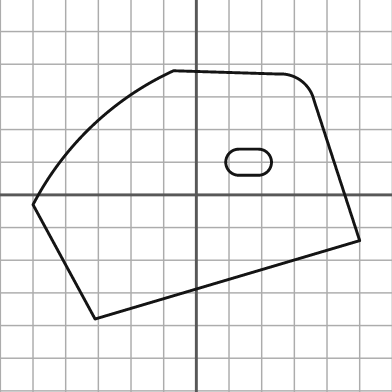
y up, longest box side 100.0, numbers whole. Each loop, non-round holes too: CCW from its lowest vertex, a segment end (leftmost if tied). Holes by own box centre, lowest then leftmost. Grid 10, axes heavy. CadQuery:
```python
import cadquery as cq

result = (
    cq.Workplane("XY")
    .moveTo(-31.0, -38.0)
    .lineTo(50.0, -14.0)
    .lineTo(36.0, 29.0)
    .threePointArc((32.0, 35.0), (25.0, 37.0))
    .lineTo(-7.0, 38.0)
    .threePointArc((-32.0, 21.0), (-50.0, -3.0))
    .close()
    .moveTo(13.0, 6.0)
    .lineTo(19.0, 6.0)
    .threePointArc((23.0, 10.0), (19.0, 14.0))
    .lineTo(13.0, 14.0)
    .threePointArc((9.0, 10.0), (13.0, 6.0))
    .close()
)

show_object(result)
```